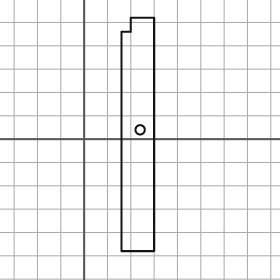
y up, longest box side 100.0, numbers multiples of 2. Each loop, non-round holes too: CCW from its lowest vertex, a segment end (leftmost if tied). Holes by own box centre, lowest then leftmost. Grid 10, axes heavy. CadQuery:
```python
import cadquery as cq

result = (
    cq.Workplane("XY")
    .moveTo(16.0, -48.0)
    .lineTo(30.0, -48.0)
    .lineTo(30.0, 52.0)
    .lineTo(20.0, 52.0)
    .lineTo(20.0, 46.0)
    .lineTo(16.0, 46.0)
    .close()
    .moveTo(24.0, 4.0)
    .circle(2.0)
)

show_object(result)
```